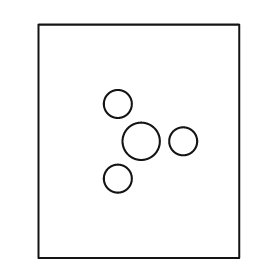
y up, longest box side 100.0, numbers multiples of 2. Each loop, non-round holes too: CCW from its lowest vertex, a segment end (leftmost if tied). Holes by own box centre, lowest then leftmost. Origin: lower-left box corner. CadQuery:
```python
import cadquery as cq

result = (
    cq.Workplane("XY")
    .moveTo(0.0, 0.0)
    .lineTo(86.0, 0.0)
    .lineTo(86.0, 100.0)
    .lineTo(0.0, 100.0)
    .close()
    .moveTo(34.0, 34.0)
    .circle(6.0)
    .moveTo(44.0, 50.0)
    .circle(8.0)
    .moveTo(62.0, 50.0)
    .circle(6.0)
    .moveTo(34.0, 66.0)
    .circle(6.0)
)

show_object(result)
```